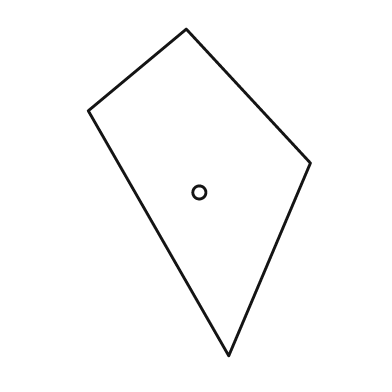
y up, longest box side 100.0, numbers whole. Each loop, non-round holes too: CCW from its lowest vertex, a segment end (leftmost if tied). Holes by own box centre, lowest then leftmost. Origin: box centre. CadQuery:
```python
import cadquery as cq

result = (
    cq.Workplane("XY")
    .moveTo(9.0, -50.0)
    .lineTo(34.0, 9.0)
    .lineTo(-4.0, 50.0)
    .lineTo(-34.0, 25.0)
    .close()
    .moveTo(0.0, 0.0)
    .circle(2.0)
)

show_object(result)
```